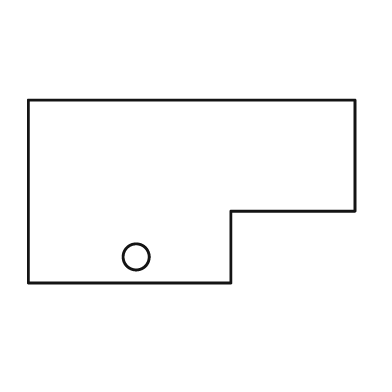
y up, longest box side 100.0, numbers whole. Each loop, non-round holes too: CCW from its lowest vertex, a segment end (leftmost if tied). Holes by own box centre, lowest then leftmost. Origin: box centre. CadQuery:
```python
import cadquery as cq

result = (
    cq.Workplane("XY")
    .moveTo(-50.0, -28.0)
    .lineTo(12.0, -28.0)
    .lineTo(12.0, -6.0)
    .lineTo(50.0, -6.0)
    .lineTo(50.0, 28.0)
    .lineTo(-50.0, 28.0)
    .close()
    .moveTo(-17.0, -20.0)
    .circle(4.0)
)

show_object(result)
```